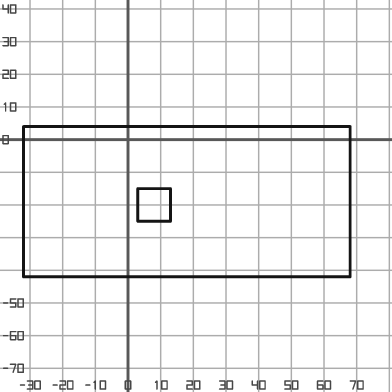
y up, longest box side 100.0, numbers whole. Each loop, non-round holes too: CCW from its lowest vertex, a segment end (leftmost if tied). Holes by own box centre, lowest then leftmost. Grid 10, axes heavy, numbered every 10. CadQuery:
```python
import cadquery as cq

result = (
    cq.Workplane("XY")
    .moveTo(-32.0, -42.0)
    .lineTo(68.0, -42.0)
    .lineTo(68.0, 4.0)
    .lineTo(-32.0, 4.0)
    .close()
    .moveTo(3.0, -25.0)
    .lineTo(13.0, -25.0)
    .lineTo(13.0, -15.0)
    .lineTo(3.0, -15.0)
    .close()
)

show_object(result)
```